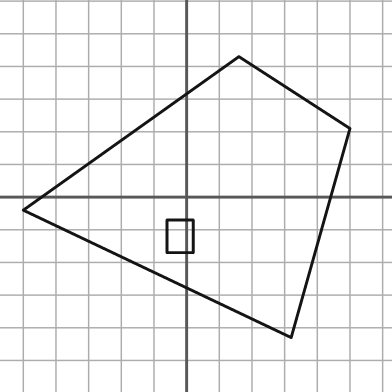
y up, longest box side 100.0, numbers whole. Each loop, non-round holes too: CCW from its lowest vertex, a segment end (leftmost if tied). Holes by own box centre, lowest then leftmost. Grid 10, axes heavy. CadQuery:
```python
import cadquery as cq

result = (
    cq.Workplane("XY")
    .moveTo(32.0, -43.0)
    .lineTo(50.0, 21.0)
    .lineTo(16.0, 43.0)
    .lineTo(-50.0, -4.0)
    .close()
    .moveTo(-6.0, -17.0)
    .lineTo(2.0, -17.0)
    .lineTo(2.0, -7.0)
    .lineTo(-6.0, -7.0)
    .close()
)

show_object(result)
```